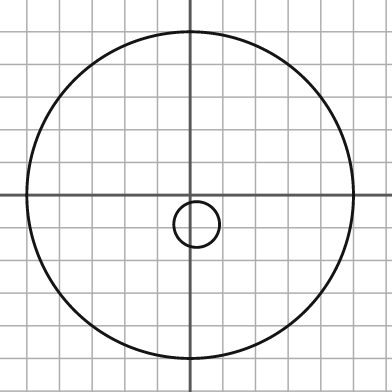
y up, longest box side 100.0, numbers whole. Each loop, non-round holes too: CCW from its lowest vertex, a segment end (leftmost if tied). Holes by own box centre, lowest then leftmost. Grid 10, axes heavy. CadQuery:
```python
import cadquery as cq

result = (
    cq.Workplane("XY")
    .moveTo(0.0, 0.0)
    .circle(50.0)
    .moveTo(2.0, -9.0)
    .circle(7.0)
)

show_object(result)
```